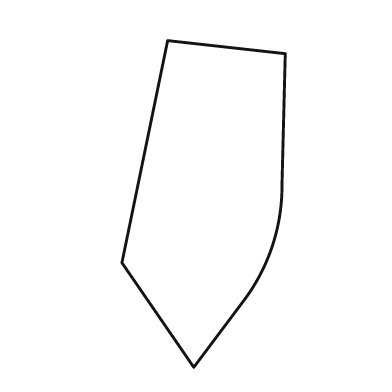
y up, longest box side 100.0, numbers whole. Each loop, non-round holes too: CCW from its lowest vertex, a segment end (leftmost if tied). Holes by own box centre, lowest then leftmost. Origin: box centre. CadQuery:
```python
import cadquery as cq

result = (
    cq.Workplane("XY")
    .moveTo(-3.0, -50.0)
    .lineTo(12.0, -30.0)
    .threePointArc((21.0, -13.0), (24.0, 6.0))
    .lineTo(25.0, 46.0)
    .lineTo(-11.0, 50.0)
    .lineTo(-25.0, -18.0)
    .close()
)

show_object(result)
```